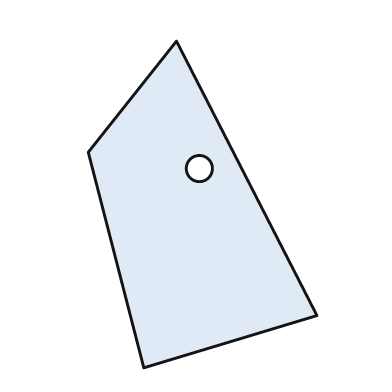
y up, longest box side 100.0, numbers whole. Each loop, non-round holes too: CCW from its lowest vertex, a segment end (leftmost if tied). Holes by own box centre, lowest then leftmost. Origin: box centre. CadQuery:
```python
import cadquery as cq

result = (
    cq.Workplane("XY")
    .moveTo(-18.0, -50.0)
    .lineTo(35.0, -34.0)
    .lineTo(-8.0, 50.0)
    .lineTo(-35.0, 16.0)
    .close()
    .moveTo(-1.0, 11.0)
    .circle(4.0)
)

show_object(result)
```